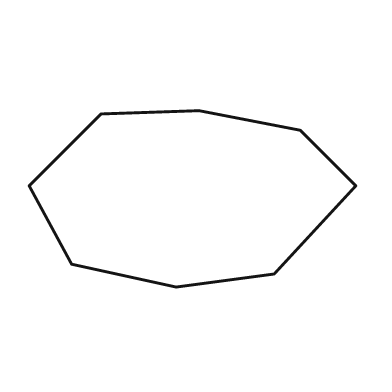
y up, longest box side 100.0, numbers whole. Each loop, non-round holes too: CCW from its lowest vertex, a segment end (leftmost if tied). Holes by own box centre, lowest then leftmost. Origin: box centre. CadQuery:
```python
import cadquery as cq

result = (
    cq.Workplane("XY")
    .moveTo(-5.0, -27.0)
    .lineTo(25.0, -23.0)
    .lineTo(50.0, 4.0)
    .lineTo(33.0, 21.0)
    .lineTo(2.0, 27.0)
    .lineTo(-28.0, 26.0)
    .lineTo(-50.0, 4.0)
    .lineTo(-37.0, -20.0)
    .close()
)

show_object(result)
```